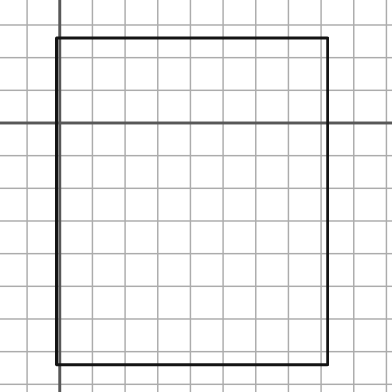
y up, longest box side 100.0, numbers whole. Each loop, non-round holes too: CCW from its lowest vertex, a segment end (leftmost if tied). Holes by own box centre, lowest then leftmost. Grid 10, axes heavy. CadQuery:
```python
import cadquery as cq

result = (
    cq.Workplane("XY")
    .moveTo(-1.0, -74.0)
    .lineTo(82.0, -74.0)
    .lineTo(82.0, 26.0)
    .lineTo(-1.0, 26.0)
    .close()
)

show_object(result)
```